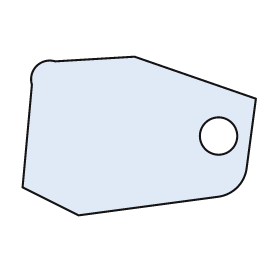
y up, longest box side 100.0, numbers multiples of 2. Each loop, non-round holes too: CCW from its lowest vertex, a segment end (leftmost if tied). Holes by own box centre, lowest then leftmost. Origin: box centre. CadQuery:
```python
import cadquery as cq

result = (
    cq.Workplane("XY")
    .moveTo(-26.0, -34.0)
    .lineTo(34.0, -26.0)
    .threePointArc((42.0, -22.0), (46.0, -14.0))
    .lineTo(50.0, 16.0)
    .lineTo(-2.0, 34.0)
    .lineTo(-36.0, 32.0)
    .threePointArc((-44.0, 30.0), (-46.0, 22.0))
    .lineTo(-50.0, -22.0)
    .close()
    .moveTo(34.0, 0.0)
    .circle(8.0)
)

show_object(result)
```